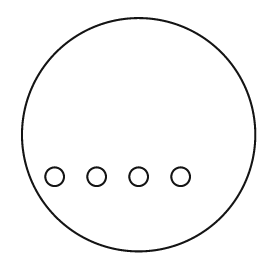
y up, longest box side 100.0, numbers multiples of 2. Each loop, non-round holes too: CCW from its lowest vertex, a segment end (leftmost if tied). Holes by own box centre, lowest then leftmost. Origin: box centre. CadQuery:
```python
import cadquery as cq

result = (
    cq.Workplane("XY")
    .moveTo(0.0, 0.0)
    .circle(50.0)
    .moveTo(-36.0, -18.0)
    .circle(4.0)
    .moveTo(-18.0, -18.0)
    .circle(4.0)
    .moveTo(0.0, -18.0)
    .circle(4.0)
    .moveTo(18.0, -18.0)
    .circle(4.0)
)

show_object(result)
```